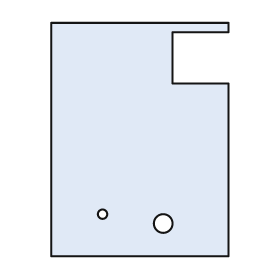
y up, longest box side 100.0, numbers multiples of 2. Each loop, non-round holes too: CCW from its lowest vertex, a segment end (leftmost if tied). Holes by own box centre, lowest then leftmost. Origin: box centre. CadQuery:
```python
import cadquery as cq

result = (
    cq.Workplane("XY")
    .moveTo(-38.0, -50.0)
    .lineTo(38.0, -50.0)
    .lineTo(38.0, 24.0)
    .lineTo(14.0, 24.0)
    .lineTo(14.0, 46.0)
    .lineTo(38.0, 46.0)
    .lineTo(38.0, 50.0)
    .lineTo(-38.0, 50.0)
    .close()
    .moveTo(10.0, -36.0)
    .circle(4.0)
    .moveTo(-16.0, -32.0)
    .circle(2.0)
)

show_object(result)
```